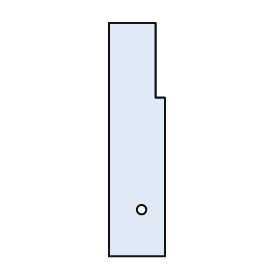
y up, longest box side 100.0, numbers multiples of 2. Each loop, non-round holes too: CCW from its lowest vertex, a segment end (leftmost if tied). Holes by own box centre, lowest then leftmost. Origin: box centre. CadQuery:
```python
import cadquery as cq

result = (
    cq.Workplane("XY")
    .moveTo(-12.0, -50.0)
    .lineTo(12.0, -50.0)
    .lineTo(12.0, 18.0)
    .lineTo(8.0, 18.0)
    .lineTo(8.0, 50.0)
    .lineTo(-12.0, 50.0)
    .close()
    .moveTo(2.0, -30.0)
    .circle(2.0)
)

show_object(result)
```